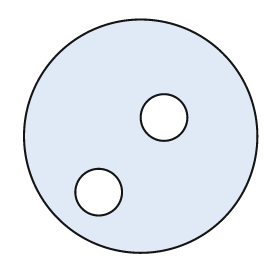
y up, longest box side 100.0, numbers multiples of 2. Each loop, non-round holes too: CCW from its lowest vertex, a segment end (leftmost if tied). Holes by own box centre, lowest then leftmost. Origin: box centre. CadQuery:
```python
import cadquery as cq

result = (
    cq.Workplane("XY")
    .moveTo(0.0, 0.0)
    .circle(50.0)
    .moveTo(-18.0, -24.0)
    .circle(10.0)
    .moveTo(10.0, 8.0)
    .circle(10.0)
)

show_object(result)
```